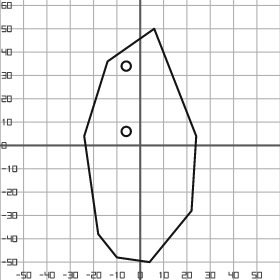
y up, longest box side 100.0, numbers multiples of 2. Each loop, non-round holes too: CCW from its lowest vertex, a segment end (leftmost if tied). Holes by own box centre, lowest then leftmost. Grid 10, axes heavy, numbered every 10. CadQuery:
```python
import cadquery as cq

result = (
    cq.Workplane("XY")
    .moveTo(4.0, -50.0)
    .lineTo(22.0, -28.0)
    .lineTo(24.0, 4.0)
    .lineTo(6.0, 50.0)
    .lineTo(-14.0, 36.0)
    .lineTo(-24.0, 4.0)
    .lineTo(-18.0, -38.0)
    .lineTo(-10.0, -48.0)
    .close()
    .moveTo(-6.0, 6.0)
    .circle(2.0)
    .moveTo(-6.0, 34.0)
    .circle(2.0)
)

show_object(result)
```